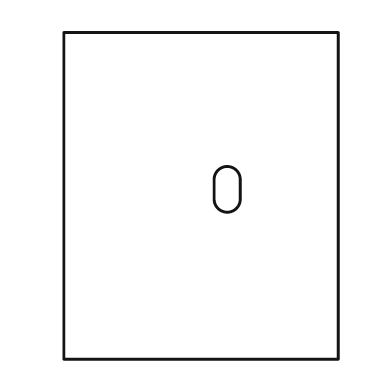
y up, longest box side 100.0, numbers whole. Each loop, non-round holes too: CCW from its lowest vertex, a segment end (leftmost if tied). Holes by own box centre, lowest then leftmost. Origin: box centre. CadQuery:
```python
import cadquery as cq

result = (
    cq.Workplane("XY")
    .moveTo(-42.0, -50.0)
    .lineTo(42.0, -50.0)
    .lineTo(42.0, 50.0)
    .lineTo(-42.0, 50.0)
    .close()
    .moveTo(4.0, -1.0)
    .threePointArc((8.0, -5.0), (12.0, -1.0))
    .lineTo(12.0, 5.0)
    .threePointArc((8.0, 9.0), (4.0, 5.0))
    .close()
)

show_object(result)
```